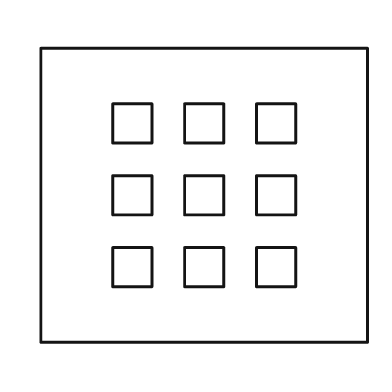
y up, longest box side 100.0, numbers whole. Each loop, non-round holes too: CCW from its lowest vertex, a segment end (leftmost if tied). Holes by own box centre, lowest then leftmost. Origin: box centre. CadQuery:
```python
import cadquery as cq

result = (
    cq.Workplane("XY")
    .moveTo(-50.0, -45.0)
    .lineTo(50.0, -45.0)
    .lineTo(50.0, 45.0)
    .lineTo(-50.0, 45.0)
    .close()
    .moveTo(-28.0, -28.0)
    .lineTo(-16.0, -28.0)
    .lineTo(-16.0, -16.0)
    .lineTo(-28.0, -16.0)
    .close()
    .moveTo(-6.0, -28.0)
    .lineTo(6.0, -28.0)
    .lineTo(6.0, -16.0)
    .lineTo(-6.0, -16.0)
    .close()
    .moveTo(16.0, -28.0)
    .lineTo(28.0, -28.0)
    .lineTo(28.0, -16.0)
    .lineTo(16.0, -16.0)
    .close()
    .moveTo(-28.0, -6.0)
    .lineTo(-16.0, -6.0)
    .lineTo(-16.0, 6.0)
    .lineTo(-28.0, 6.0)
    .close()
    .moveTo(-6.0, -6.0)
    .lineTo(6.0, -6.0)
    .lineTo(6.0, 6.0)
    .lineTo(-6.0, 6.0)
    .close()
    .moveTo(16.0, -6.0)
    .lineTo(28.0, -6.0)
    .lineTo(28.0, 6.0)
    .lineTo(16.0, 6.0)
    .close()
    .moveTo(-28.0, 16.0)
    .lineTo(-16.0, 16.0)
    .lineTo(-16.0, 28.0)
    .lineTo(-28.0, 28.0)
    .close()
    .moveTo(-6.0, 16.0)
    .lineTo(6.0, 16.0)
    .lineTo(6.0, 28.0)
    .lineTo(-6.0, 28.0)
    .close()
    .moveTo(16.0, 16.0)
    .lineTo(28.0, 16.0)
    .lineTo(28.0, 28.0)
    .lineTo(16.0, 28.0)
    .close()
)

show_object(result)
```